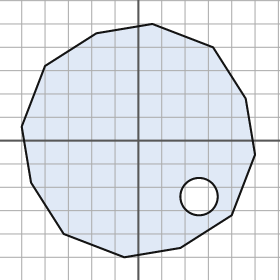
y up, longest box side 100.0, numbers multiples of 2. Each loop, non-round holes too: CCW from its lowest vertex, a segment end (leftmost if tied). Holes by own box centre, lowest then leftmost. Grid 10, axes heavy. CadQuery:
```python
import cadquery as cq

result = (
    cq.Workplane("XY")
    .moveTo(-6.0, -50.0)
    .lineTo(18.0, -46.0)
    .lineTo(40.0, -32.0)
    .lineTo(50.0, -6.0)
    .lineTo(46.0, 18.0)
    .lineTo(32.0, 40.0)
    .lineTo(6.0, 50.0)
    .lineTo(-18.0, 46.0)
    .lineTo(-40.0, 32.0)
    .lineTo(-50.0, 6.0)
    .lineTo(-46.0, -18.0)
    .lineTo(-32.0, -40.0)
    .close()
    .moveTo(26.0, -24.0)
    .circle(8.0)
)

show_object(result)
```